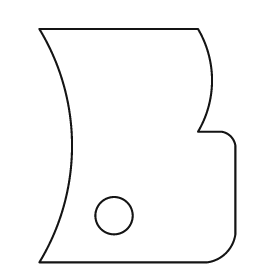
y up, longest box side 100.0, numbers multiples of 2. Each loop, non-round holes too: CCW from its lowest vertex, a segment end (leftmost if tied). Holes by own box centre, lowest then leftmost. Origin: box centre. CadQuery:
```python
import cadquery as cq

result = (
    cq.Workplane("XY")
    .moveTo(-42.0, -50.0)
    .lineTo(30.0, -50.0)
    .threePointArc((38.0, -46.0), (42.0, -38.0))
    .lineTo(42.0, 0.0)
    .threePointArc((40.0, 4.0), (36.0, 6.0))
    .lineTo(26.0, 6.0)
    .threePointArc((32.0, 28.0), (26.0, 50.0))
    .lineTo(-42.0, 50.0)
    .threePointArc((-28.0, 0.0), (-42.0, -50.0))
    .close()
    .moveTo(-10.0, -30.0)
    .circle(8.0)
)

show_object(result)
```